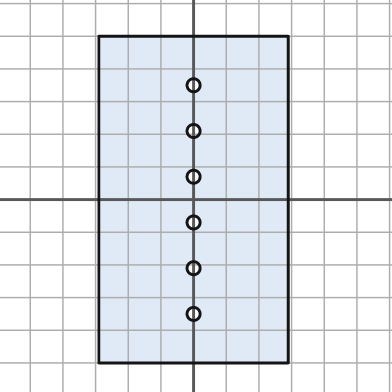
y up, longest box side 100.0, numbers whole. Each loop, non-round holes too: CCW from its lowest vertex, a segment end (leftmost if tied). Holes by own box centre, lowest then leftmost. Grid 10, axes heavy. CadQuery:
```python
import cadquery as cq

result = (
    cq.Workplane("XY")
    .moveTo(-29.0, -50.0)
    .lineTo(29.0, -50.0)
    .lineTo(29.0, 50.0)
    .lineTo(-29.0, 50.0)
    .close()
    .moveTo(0.0, -35.0)
    .circle(2.0)
    .moveTo(0.0, -21.0)
    .circle(2.0)
    .moveTo(0.0, -7.0)
    .circle(2.0)
    .moveTo(0.0, 7.0)
    .circle(2.0)
    .moveTo(0.0, 21.0)
    .circle(2.0)
    .moveTo(0.0, 35.0)
    .circle(2.0)
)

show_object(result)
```